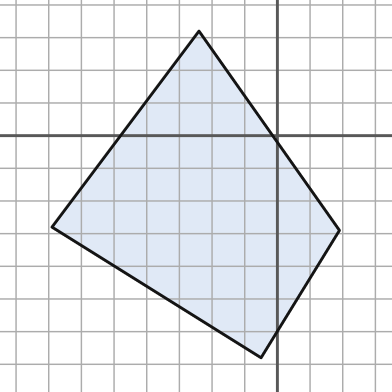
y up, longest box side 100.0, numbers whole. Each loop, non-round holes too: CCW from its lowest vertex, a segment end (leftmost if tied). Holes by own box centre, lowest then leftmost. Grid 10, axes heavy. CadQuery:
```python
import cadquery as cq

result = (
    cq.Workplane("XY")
    .moveTo(-5.0, -68.0)
    .lineTo(19.0, -29.0)
    .lineTo(-24.0, 32.0)
    .lineTo(-69.0, -28.0)
    .close()
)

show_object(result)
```